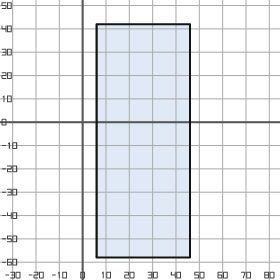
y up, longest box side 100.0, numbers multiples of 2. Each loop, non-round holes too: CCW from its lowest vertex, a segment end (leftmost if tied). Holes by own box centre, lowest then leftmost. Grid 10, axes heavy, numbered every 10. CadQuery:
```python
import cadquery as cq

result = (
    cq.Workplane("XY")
    .moveTo(6.0, -58.0)
    .lineTo(46.0, -58.0)
    .lineTo(46.0, 42.0)
    .lineTo(6.0, 42.0)
    .close()
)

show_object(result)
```